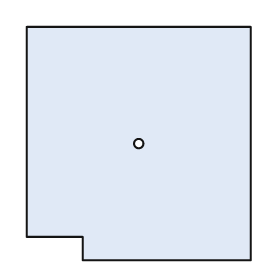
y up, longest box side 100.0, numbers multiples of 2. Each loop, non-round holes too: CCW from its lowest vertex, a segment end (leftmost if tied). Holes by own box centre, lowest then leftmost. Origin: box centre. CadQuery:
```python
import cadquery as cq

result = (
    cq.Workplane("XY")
    .moveTo(-24.0, -50.0)
    .lineTo(48.0, -50.0)
    .lineTo(48.0, 50.0)
    .lineTo(-48.0, 50.0)
    .lineTo(-48.0, -40.0)
    .lineTo(-24.0, -40.0)
    .close()
    .moveTo(0.0, 0.0)
    .circle(2.0)
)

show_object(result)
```